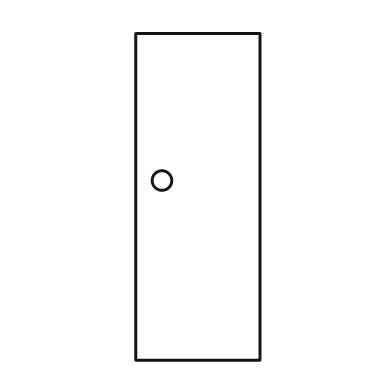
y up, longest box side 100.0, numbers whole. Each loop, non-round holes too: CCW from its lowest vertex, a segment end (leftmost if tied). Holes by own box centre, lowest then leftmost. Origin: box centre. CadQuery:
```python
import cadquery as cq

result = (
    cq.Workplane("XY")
    .moveTo(-19.0, -50.0)
    .lineTo(19.0, -50.0)
    .lineTo(19.0, 50.0)
    .lineTo(-19.0, 50.0)
    .close()
    .moveTo(-11.0, 5.0)
    .circle(3.0)
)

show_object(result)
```